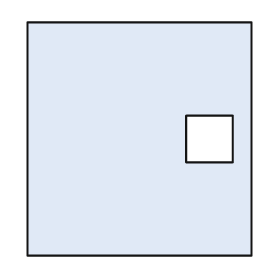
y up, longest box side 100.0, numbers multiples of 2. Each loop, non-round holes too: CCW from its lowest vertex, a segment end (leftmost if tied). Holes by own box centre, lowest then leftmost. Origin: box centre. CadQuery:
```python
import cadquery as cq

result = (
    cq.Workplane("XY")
    .moveTo(-48.0, -50.0)
    .lineTo(48.0, -50.0)
    .lineTo(48.0, 50.0)
    .lineTo(-48.0, 50.0)
    .close()
    .moveTo(20.0, -10.0)
    .lineTo(40.0, -10.0)
    .lineTo(40.0, 10.0)
    .lineTo(20.0, 10.0)
    .close()
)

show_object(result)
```